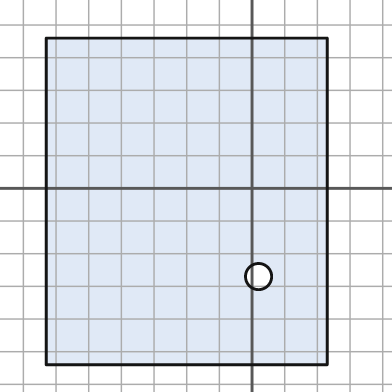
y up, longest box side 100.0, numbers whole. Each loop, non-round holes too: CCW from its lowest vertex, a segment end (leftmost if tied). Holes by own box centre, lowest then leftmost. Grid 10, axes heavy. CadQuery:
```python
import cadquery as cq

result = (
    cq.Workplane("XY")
    .moveTo(-63.0, -54.0)
    .lineTo(23.0, -54.0)
    .lineTo(23.0, 46.0)
    .lineTo(-63.0, 46.0)
    .close()
    .moveTo(2.0, -27.0)
    .circle(4.0)
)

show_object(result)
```